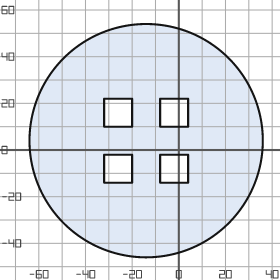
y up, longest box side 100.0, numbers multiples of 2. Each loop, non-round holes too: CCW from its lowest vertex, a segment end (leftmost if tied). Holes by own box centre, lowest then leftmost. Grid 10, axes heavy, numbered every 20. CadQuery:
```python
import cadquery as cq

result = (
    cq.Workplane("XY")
    .moveTo(-14.0, 4.0)
    .circle(50.0)
    .moveTo(-32.0, -14.0)
    .lineTo(-20.0, -14.0)
    .lineTo(-20.0, -2.0)
    .lineTo(-32.0, -2.0)
    .close()
    .moveTo(-8.0, -14.0)
    .lineTo(4.0, -14.0)
    .lineTo(4.0, -2.0)
    .lineTo(-8.0, -2.0)
    .close()
    .moveTo(-32.0, 10.0)
    .lineTo(-20.0, 10.0)
    .lineTo(-20.0, 22.0)
    .lineTo(-32.0, 22.0)
    .close()
    .moveTo(-8.0, 10.0)
    .lineTo(4.0, 10.0)
    .lineTo(4.0, 22.0)
    .lineTo(-8.0, 22.0)
    .close()
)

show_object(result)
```